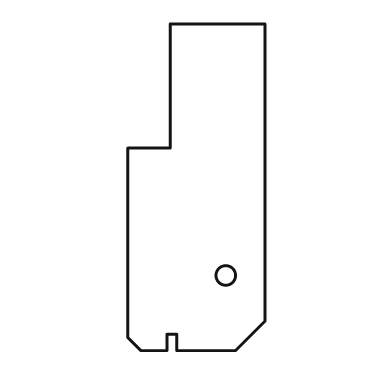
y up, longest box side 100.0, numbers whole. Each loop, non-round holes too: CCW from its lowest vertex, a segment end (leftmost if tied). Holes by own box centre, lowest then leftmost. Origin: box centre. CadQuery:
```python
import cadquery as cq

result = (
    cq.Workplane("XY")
    .moveTo(-17.0, -50.0)
    .lineTo(-9.0, -50.0)
    .lineTo(-9.0, -45.0)
    .lineTo(-6.0, -45.0)
    .lineTo(-6.0, -50.0)
    .lineTo(12.0, -50.0)
    .lineTo(21.0, -41.0)
    .lineTo(21.0, 50.0)
    .lineTo(-8.0, 50.0)
    .lineTo(-8.0, 12.0)
    .lineTo(-21.0, 12.0)
    .lineTo(-21.0, -46.0)
    .close()
    .moveTo(9.0, -27.0)
    .circle(3.0)
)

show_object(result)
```